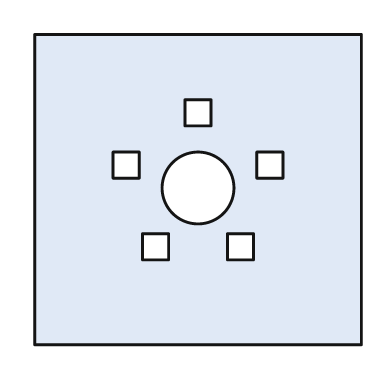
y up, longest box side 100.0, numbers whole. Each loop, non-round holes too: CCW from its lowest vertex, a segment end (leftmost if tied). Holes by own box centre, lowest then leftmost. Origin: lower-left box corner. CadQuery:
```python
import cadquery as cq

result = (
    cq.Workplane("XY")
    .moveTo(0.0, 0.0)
    .lineTo(100.0, 0.0)
    .lineTo(100.0, 95.0)
    .lineTo(0.0, 95.0)
    .close()
    .moveTo(33.0, 26.0)
    .lineTo(41.0, 26.0)
    .lineTo(41.0, 34.0)
    .lineTo(33.0, 34.0)
    .close()
    .moveTo(59.0, 26.0)
    .lineTo(67.0, 26.0)
    .lineTo(67.0, 34.0)
    .lineTo(59.0, 34.0)
    .close()
    .moveTo(50.0, 48.0)
    .circle(11.0)
    .moveTo(24.0, 51.0)
    .lineTo(32.0, 51.0)
    .lineTo(32.0, 59.0)
    .lineTo(24.0, 59.0)
    .close()
    .moveTo(68.0, 51.0)
    .lineTo(76.0, 51.0)
    .lineTo(76.0, 59.0)
    .lineTo(68.0, 59.0)
    .close()
    .moveTo(46.0, 67.0)
    .lineTo(54.0, 67.0)
    .lineTo(54.0, 75.0)
    .lineTo(46.0, 75.0)
    .close()
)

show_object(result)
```